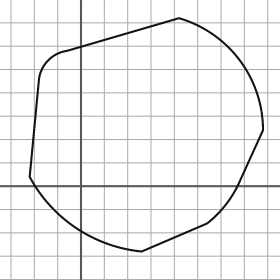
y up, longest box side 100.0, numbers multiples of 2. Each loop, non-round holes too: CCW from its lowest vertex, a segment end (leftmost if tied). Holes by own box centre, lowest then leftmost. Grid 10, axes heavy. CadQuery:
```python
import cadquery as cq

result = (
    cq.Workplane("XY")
    .moveTo(26.0, -28.0)
    .lineTo(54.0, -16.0)
    .threePointArc((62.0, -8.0), (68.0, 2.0))
    .lineTo(78.0, 24.0)
    .threePointArc((68.0, 54.0), (42.0, 72.0))
    .lineTo(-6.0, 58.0)
    .threePointArc((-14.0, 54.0), (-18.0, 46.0))
    .lineTo(-22.0, 4.0)
    .threePointArc((-2.0, -18.0), (26.0, -28.0))
    .close()
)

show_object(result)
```